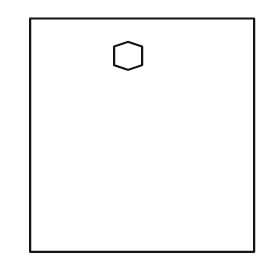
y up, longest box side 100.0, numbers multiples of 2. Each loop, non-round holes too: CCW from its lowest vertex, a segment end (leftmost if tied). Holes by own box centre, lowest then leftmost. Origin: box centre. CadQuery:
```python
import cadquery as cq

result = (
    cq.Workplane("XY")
    .moveTo(-48.0, -50.0)
    .lineTo(48.0, -50.0)
    .lineTo(48.0, 50.0)
    .lineTo(-48.0, 50.0)
    .close()
    .moveTo(-6.0, 28.0)
    .lineTo(0.0, 30.0)
    .lineTo(0.0, 38.0)
    .lineTo(-6.0, 40.0)
    .lineTo(-12.0, 38.0)
    .lineTo(-12.0, 30.0)
    .close()
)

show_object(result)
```